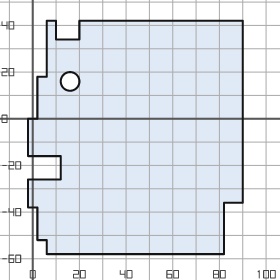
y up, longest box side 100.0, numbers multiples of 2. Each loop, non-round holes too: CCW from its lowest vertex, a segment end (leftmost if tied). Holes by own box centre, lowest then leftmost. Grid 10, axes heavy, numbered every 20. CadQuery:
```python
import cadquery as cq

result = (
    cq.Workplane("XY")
    .moveTo(6.0, -58.0)
    .lineTo(82.0, -58.0)
    .lineTo(82.0, -36.0)
    .lineTo(90.0, -36.0)
    .lineTo(90.0, 42.0)
    .lineTo(20.0, 42.0)
    .lineTo(20.0, 34.0)
    .lineTo(10.0, 34.0)
    .lineTo(10.0, 42.0)
    .lineTo(6.0, 42.0)
    .lineTo(6.0, 18.0)
    .lineTo(2.0, 18.0)
    .lineTo(2.0, 0.0)
    .lineTo(-2.0, 0.0)
    .lineTo(-2.0, -16.0)
    .lineTo(12.0, -16.0)
    .lineTo(12.0, -26.0)
    .lineTo(-2.0, -26.0)
    .lineTo(-2.0, -38.0)
    .lineTo(2.0, -38.0)
    .lineTo(2.0, -52.0)
    .lineTo(6.0, -52.0)
    .close()
    .moveTo(16.0, 16.0)
    .circle(4.0)
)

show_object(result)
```